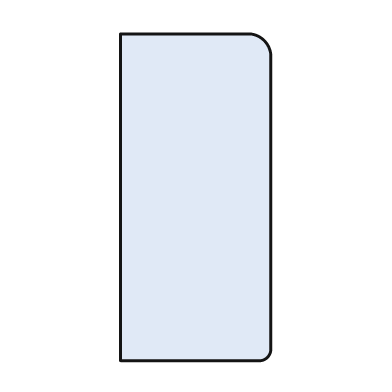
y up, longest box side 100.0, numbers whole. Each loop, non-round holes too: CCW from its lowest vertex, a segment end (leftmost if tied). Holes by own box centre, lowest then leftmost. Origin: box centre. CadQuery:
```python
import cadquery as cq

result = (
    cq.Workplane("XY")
    .moveTo(-23.0, -50.0)
    .lineTo(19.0, -50.0)
    .threePointArc((22.0, -49.0), (23.0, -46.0))
    .lineTo(23.0, 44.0)
    .threePointArc((21.0, 48.0), (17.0, 50.0))
    .lineTo(-23.0, 50.0)
    .close()
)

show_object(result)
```